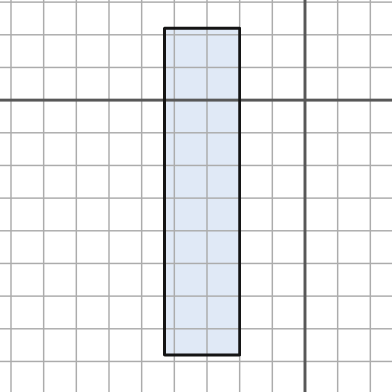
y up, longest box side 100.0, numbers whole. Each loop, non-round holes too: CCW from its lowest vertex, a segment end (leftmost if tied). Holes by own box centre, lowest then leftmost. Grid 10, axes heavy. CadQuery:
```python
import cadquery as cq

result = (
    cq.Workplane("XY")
    .moveTo(-43.0, -78.0)
    .lineTo(-20.0, -78.0)
    .lineTo(-20.0, 22.0)
    .lineTo(-43.0, 22.0)
    .close()
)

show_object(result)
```